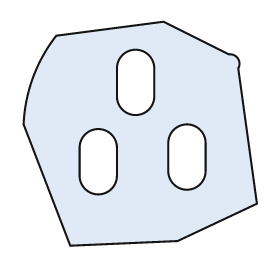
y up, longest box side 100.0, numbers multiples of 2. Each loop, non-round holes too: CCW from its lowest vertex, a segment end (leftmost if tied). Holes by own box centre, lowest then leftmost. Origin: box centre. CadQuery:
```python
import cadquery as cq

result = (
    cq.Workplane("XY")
    .moveTo(-30.0, -48.0)
    .lineTo(16.0, -46.0)
    .lineTo(50.0, -30.0)
    .lineTo(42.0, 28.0)
    .threePointArc((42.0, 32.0), (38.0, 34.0))
    .lineTo(10.0, 48.0)
    .lineTo(-36.0, 42.0)
    .threePointArc((-46.0, 24.0), (-50.0, 4.0))
    .close()
    .moveTo(-26.0, -18.0)
    .threePointArc((-18.0, -26.0), (-10.0, -18.0))
    .lineTo(-10.0, -6.0)
    .threePointArc((-18.0, 2.0), (-26.0, -6.0))
    .close()
    .moveTo(12.0, -16.0)
    .threePointArc((20.0, -24.0), (28.0, -16.0))
    .lineTo(28.0, -4.0)
    .threePointArc((20.0, 4.0), (12.0, -4.0))
    .close()
    .moveTo(-10.0, 16.0)
    .threePointArc((-2.0, 8.0), (6.0, 16.0))
    .lineTo(6.0, 28.0)
    .threePointArc((-2.0, 36.0), (-10.0, 28.0))
    .close()
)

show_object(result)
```